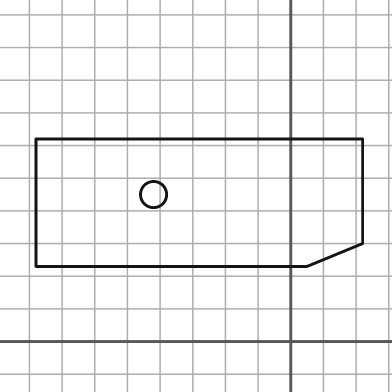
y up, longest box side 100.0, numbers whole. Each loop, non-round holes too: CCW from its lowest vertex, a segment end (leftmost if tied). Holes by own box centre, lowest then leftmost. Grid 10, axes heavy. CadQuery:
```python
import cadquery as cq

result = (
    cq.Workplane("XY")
    .moveTo(-78.0, 23.0)
    .lineTo(5.0, 23.0)
    .lineTo(22.0, 30.0)
    .lineTo(22.0, 62.0)
    .lineTo(-78.0, 62.0)
    .close()
    .moveTo(-42.0, 45.0)
    .circle(4.0)
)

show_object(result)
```